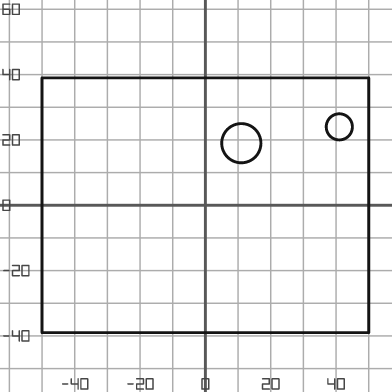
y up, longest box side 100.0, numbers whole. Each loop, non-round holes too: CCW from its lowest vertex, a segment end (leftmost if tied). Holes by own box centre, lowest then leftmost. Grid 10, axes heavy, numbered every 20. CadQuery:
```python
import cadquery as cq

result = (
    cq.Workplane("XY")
    .moveTo(-50.0, -39.0)
    .lineTo(50.0, -39.0)
    .lineTo(50.0, 39.0)
    .lineTo(-50.0, 39.0)
    .close()
    .moveTo(11.0, 19.0)
    .circle(6.0)
    .moveTo(41.0, 24.0)
    .circle(4.0)
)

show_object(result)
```